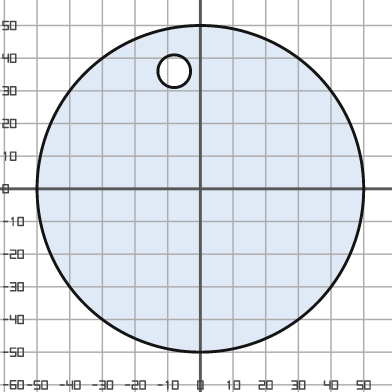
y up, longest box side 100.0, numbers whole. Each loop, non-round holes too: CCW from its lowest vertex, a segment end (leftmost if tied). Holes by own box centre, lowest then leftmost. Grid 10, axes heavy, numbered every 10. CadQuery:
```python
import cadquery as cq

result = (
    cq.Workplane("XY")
    .moveTo(0.0, 0.0)
    .circle(50.0)
    .moveTo(-8.0, 36.0)
    .circle(5.0)
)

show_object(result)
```